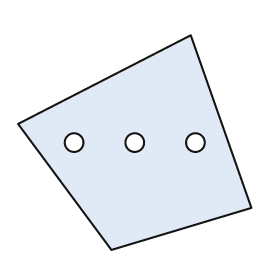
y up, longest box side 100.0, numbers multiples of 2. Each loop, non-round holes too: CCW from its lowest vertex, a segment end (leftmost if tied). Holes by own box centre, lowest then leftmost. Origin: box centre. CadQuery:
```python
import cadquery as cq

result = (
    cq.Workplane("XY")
    .moveTo(-10.0, -46.0)
    .lineTo(50.0, -28.0)
    .lineTo(24.0, 46.0)
    .lineTo(-50.0, 8.0)
    .close()
    .moveTo(-26.0, 0.0)
    .circle(4.0)
    .moveTo(0.0, 0.0)
    .circle(4.0)
    .moveTo(26.0, 0.0)
    .circle(4.0)
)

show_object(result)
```